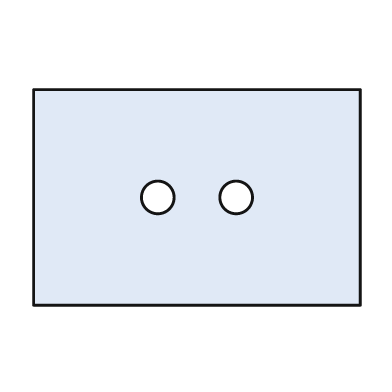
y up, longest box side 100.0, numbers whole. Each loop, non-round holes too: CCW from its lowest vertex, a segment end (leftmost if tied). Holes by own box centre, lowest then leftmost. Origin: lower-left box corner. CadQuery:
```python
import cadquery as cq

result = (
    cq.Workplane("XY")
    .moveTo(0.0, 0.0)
    .lineTo(100.0, 0.0)
    .lineTo(100.0, 66.0)
    .lineTo(0.0, 66.0)
    .close()
    .moveTo(38.0, 33.0)
    .circle(5.0)
    .moveTo(62.0, 33.0)
    .circle(5.0)
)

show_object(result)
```